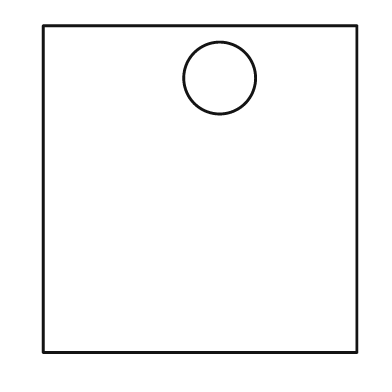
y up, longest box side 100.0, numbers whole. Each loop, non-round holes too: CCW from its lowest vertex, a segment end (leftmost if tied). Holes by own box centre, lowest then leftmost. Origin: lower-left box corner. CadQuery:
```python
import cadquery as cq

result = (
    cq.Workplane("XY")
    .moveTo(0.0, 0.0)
    .lineTo(96.0, 0.0)
    .lineTo(96.0, 100.0)
    .lineTo(0.0, 100.0)
    .close()
    .moveTo(54.0, 84.0)
    .circle(11.0)
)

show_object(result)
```